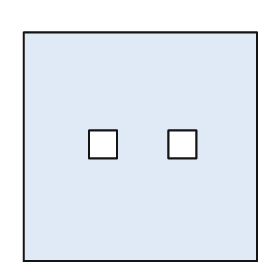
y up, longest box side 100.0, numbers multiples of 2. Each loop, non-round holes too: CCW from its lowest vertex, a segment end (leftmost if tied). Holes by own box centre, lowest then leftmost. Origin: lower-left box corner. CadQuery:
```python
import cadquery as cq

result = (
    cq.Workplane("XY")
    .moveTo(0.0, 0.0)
    .lineTo(100.0, 0.0)
    .lineTo(100.0, 98.0)
    .lineTo(0.0, 98.0)
    .close()
    .moveTo(28.0, 44.0)
    .lineTo(40.0, 44.0)
    .lineTo(40.0, 56.0)
    .lineTo(28.0, 56.0)
    .close()
    .moveTo(62.0, 44.0)
    .lineTo(74.0, 44.0)
    .lineTo(74.0, 56.0)
    .lineTo(62.0, 56.0)
    .close()
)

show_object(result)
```